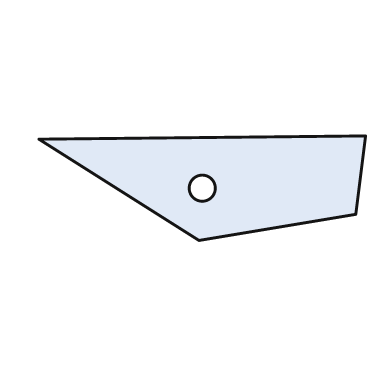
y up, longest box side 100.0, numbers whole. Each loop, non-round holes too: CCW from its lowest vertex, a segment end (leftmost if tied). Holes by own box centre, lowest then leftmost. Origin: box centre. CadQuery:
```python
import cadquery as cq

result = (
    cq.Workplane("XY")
    .moveTo(-1.0, -16.0)
    .lineTo(47.0, -8.0)
    .lineTo(50.0, 16.0)
    .lineTo(-50.0, 15.0)
    .close()
    .moveTo(0.0, 0.0)
    .circle(4.0)
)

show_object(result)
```